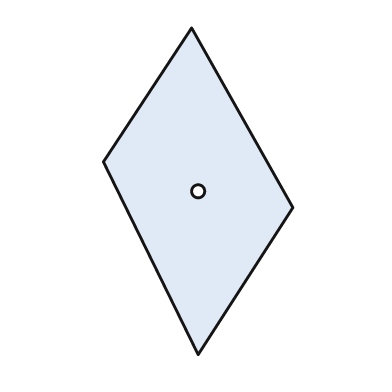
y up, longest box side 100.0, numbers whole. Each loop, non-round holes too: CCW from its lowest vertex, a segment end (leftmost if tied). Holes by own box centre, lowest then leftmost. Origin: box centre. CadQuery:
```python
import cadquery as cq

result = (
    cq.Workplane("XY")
    .moveTo(0.0, -50.0)
    .lineTo(29.0, -5.0)
    .lineTo(-2.0, 50.0)
    .lineTo(-29.0, 9.0)
    .close()
    .moveTo(0.0, 0.0)
    .circle(2.0)
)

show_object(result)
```